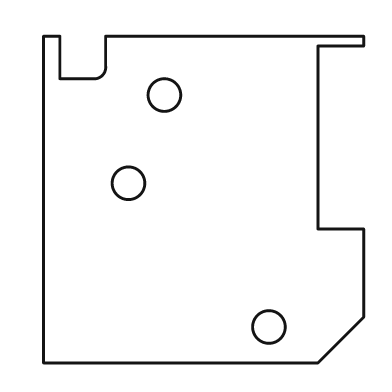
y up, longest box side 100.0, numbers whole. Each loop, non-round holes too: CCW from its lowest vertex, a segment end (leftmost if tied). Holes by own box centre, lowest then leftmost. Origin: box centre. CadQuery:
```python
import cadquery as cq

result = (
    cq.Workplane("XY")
    .moveTo(-49.0, -50.0)
    .lineTo(35.0, -50.0)
    .lineTo(49.0, -36.0)
    .lineTo(49.0, -9.0)
    .lineTo(35.0, -9.0)
    .lineTo(35.0, 47.0)
    .lineTo(49.0, 47.0)
    .lineTo(49.0, 50.0)
    .lineTo(-30.0, 50.0)
    .lineTo(-30.0, 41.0)
    .threePointArc((-31.0, 38.0), (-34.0, 37.0))
    .lineTo(-44.0, 37.0)
    .lineTo(-44.0, 50.0)
    .lineTo(-49.0, 50.0)
    .close()
    .moveTo(20.0, -39.0)
    .circle(5.0)
    .moveTo(-23.0, 5.0)
    .circle(5.0)
    .moveTo(-12.0, 32.0)
    .circle(5.0)
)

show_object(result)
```